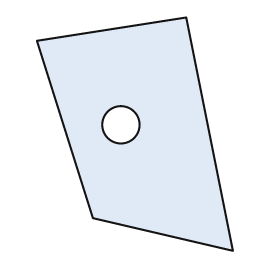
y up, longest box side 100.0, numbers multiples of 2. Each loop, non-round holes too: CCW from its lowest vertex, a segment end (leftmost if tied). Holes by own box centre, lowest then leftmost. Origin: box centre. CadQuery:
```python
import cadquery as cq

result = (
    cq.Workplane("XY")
    .moveTo(42.0, -50.0)
    .lineTo(22.0, 50.0)
    .lineTo(-42.0, 40.0)
    .lineTo(-18.0, -36.0)
    .close()
    .moveTo(-6.0, 4.0)
    .circle(8.0)
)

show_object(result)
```